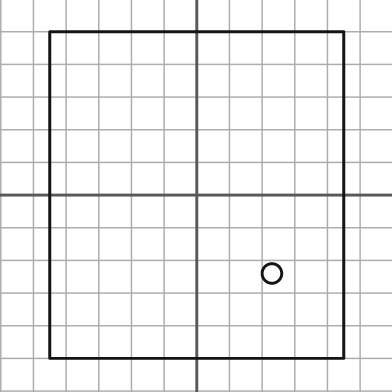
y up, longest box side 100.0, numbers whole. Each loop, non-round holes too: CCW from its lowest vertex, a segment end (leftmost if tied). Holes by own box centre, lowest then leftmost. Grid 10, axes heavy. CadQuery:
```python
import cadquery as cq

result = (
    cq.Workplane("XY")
    .moveTo(-45.0, -50.0)
    .lineTo(45.0, -50.0)
    .lineTo(45.0, 50.0)
    .lineTo(-45.0, 50.0)
    .close()
    .moveTo(23.0, -24.0)
    .circle(3.0)
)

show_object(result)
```